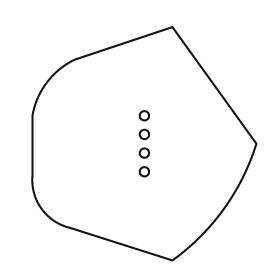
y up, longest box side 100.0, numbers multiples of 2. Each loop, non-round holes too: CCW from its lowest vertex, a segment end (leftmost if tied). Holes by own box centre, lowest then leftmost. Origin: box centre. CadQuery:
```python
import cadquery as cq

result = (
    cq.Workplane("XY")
    .moveTo(12.0, -50.0)
    .threePointArc((34.0, -28.0), (48.0, 0.0))
    .lineTo(12.0, 50.0)
    .lineTo(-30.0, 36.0)
    .threePointArc((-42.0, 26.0), (-48.0, 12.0))
    .lineTo(-48.0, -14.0)
    .threePointArc((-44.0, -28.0), (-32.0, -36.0))
    .close()
    .moveTo(0.0, -12.0)
    .circle(2.0)
    .moveTo(0.0, -4.0)
    .circle(2.0)
    .moveTo(0.0, 4.0)
    .circle(2.0)
    .moveTo(0.0, 12.0)
    .circle(2.0)
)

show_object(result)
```